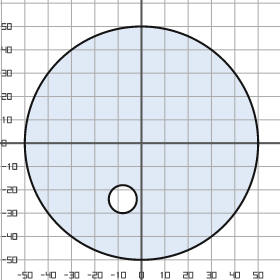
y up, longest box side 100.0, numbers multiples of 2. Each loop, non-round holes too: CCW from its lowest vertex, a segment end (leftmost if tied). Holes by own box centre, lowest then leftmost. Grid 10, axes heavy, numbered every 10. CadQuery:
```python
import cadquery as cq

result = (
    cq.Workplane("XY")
    .moveTo(0.0, 0.0)
    .circle(50.0)
    .moveTo(-8.0, -24.0)
    .circle(6.0)
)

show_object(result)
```